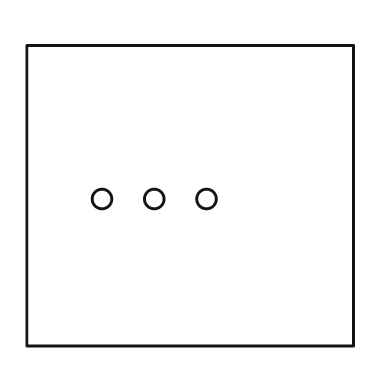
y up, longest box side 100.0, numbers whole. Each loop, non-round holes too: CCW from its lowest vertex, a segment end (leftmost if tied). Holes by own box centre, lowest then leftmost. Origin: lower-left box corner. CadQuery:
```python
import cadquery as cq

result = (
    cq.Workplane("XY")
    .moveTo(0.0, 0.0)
    .lineTo(100.0, 0.0)
    .lineTo(100.0, 92.0)
    .lineTo(0.0, 92.0)
    .close()
    .moveTo(23.0, 45.0)
    .circle(3.0)
    .moveTo(39.0, 45.0)
    .circle(3.0)
    .moveTo(55.0, 45.0)
    .circle(3.0)
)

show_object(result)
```